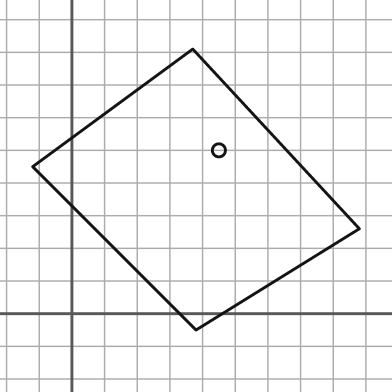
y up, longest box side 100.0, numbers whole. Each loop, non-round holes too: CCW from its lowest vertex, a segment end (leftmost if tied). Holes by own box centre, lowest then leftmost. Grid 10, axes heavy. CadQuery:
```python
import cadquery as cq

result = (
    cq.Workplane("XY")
    .moveTo(38.0, -5.0)
    .lineTo(88.0, 26.0)
    .lineTo(37.0, 81.0)
    .lineTo(-12.0, 45.0)
    .close()
    .moveTo(45.0, 50.0)
    .circle(2.0)
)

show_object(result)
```